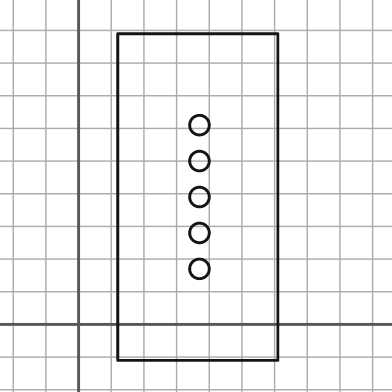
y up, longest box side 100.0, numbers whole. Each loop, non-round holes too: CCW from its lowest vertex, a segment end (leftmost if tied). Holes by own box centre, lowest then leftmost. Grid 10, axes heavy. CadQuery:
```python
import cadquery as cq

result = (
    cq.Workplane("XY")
    .moveTo(12.0, -11.0)
    .lineTo(61.0, -11.0)
    .lineTo(61.0, 89.0)
    .lineTo(12.0, 89.0)
    .close()
    .moveTo(37.0, 17.0)
    .circle(3.0)
    .moveTo(37.0, 28.0)
    .circle(3.0)
    .moveTo(37.0, 39.0)
    .circle(3.0)
    .moveTo(37.0, 50.0)
    .circle(3.0)
    .moveTo(37.0, 61.0)
    .circle(3.0)
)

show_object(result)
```